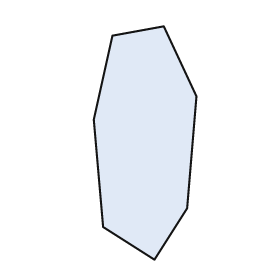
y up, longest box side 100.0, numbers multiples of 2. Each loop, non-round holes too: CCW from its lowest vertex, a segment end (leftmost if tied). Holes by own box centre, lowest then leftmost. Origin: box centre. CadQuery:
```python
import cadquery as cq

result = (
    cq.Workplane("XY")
    .moveTo(4.0, -50.0)
    .lineTo(18.0, -28.0)
    .lineTo(22.0, 20.0)
    .lineTo(8.0, 50.0)
    .lineTo(-14.0, 46.0)
    .lineTo(-22.0, 10.0)
    .lineTo(-18.0, -36.0)
    .close()
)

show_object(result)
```